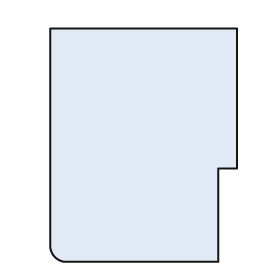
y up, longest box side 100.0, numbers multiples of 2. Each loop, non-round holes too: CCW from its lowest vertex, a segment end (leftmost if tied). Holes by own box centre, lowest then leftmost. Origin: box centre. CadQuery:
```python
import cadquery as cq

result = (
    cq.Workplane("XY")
    .moveTo(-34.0, -50.0)
    .lineTo(32.0, -50.0)
    .lineTo(32.0, -10.0)
    .lineTo(40.0, -10.0)
    .lineTo(40.0, 50.0)
    .lineTo(-40.0, 50.0)
    .lineTo(-40.0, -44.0)
    .threePointArc((-38.0, -48.0), (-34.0, -50.0))
    .close()
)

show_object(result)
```